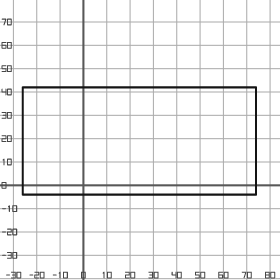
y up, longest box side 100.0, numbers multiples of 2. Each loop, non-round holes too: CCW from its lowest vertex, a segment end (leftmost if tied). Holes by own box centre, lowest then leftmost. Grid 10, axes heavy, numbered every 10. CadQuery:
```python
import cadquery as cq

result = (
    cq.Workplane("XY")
    .moveTo(-26.0, -4.0)
    .lineTo(74.0, -4.0)
    .lineTo(74.0, 42.0)
    .lineTo(-26.0, 42.0)
    .close()
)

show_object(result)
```